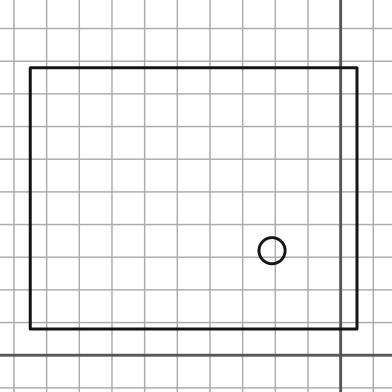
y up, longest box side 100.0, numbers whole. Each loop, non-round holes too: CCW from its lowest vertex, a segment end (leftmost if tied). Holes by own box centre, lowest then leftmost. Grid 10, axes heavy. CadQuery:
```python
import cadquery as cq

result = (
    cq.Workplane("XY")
    .moveTo(-95.0, 8.0)
    .lineTo(5.0, 8.0)
    .lineTo(5.0, 88.0)
    .lineTo(-95.0, 88.0)
    .close()
    .moveTo(-21.0, 32.0)
    .circle(4.0)
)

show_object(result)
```